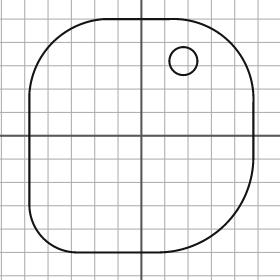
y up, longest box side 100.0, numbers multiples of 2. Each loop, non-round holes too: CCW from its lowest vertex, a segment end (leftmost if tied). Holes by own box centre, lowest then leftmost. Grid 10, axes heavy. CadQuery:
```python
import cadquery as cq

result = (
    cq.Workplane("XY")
    .moveTo(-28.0, -50.0)
    .lineTo(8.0, -50.0)
    .threePointArc((36.0, -38.0), (48.0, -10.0))
    .lineTo(48.0, 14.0)
    .threePointArc((38.0, 40.0), (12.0, 50.0))
    .lineTo(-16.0, 50.0)
    .threePointArc((-38.0, 40.0), (-48.0, 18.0))
    .lineTo(-48.0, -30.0)
    .threePointArc((-42.0, -44.0), (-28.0, -50.0))
    .close()
    .moveTo(18.0, 32.0)
    .circle(6.0)
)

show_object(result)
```